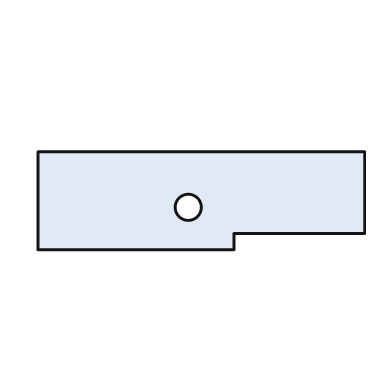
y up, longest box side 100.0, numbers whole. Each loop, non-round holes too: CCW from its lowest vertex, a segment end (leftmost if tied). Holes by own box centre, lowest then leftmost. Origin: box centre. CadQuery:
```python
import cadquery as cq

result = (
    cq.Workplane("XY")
    .moveTo(-50.0, -15.0)
    .lineTo(10.0, -15.0)
    .lineTo(10.0, -10.0)
    .lineTo(50.0, -10.0)
    .lineTo(50.0, 15.0)
    .lineTo(-50.0, 15.0)
    .close()
    .moveTo(-4.0, -2.0)
    .circle(4.0)
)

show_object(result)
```